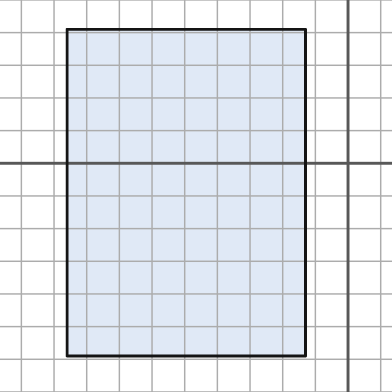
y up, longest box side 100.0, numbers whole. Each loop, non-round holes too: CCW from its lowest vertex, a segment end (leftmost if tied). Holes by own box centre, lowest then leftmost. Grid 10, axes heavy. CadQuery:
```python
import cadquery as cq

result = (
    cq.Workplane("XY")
    .moveTo(-86.0, -59.0)
    .lineTo(-13.0, -59.0)
    .lineTo(-13.0, 41.0)
    .lineTo(-86.0, 41.0)
    .close()
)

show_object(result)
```